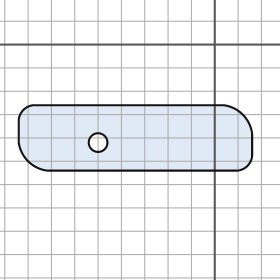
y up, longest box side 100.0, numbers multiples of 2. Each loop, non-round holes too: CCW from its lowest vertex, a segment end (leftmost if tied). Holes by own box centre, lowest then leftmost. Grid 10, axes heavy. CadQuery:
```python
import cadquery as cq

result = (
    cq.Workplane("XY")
    .moveTo(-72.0, -54.0)
    .lineTo(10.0, -54.0)
    .threePointArc((14.0, -52.0), (16.0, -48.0))
    .lineTo(16.0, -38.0)
    .threePointArc((12.0, -30.0), (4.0, -26.0))
    .lineTo(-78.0, -26.0)
    .threePointArc((-82.0, -28.0), (-84.0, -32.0))
    .lineTo(-84.0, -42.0)
    .threePointArc((-80.0, -50.0), (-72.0, -54.0))
    .close()
    .moveTo(-50.0, -42.0)
    .circle(4.0)
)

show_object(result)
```